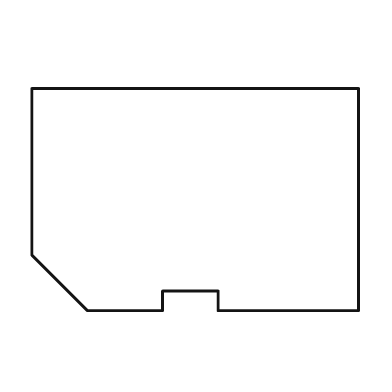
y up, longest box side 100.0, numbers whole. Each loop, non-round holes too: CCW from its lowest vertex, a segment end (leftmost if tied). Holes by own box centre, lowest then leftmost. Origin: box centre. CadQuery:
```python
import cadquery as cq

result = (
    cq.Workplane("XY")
    .moveTo(-33.0, -34.0)
    .lineTo(-10.0, -34.0)
    .lineTo(-10.0, -28.0)
    .lineTo(7.0, -28.0)
    .lineTo(7.0, -34.0)
    .lineTo(50.0, -34.0)
    .lineTo(50.0, 34.0)
    .lineTo(-50.0, 34.0)
    .lineTo(-50.0, -17.0)
    .close()
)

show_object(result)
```